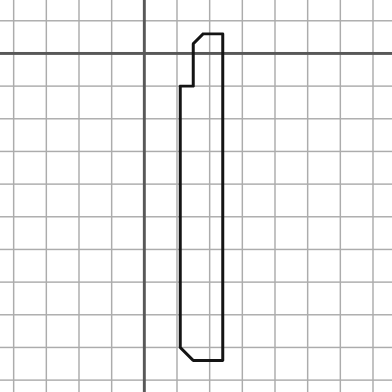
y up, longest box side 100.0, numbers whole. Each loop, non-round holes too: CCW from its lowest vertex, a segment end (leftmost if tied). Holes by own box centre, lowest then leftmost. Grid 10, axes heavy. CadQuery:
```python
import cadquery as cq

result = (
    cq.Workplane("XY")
    .moveTo(15.0, -94.0)
    .lineTo(24.0, -94.0)
    .lineTo(24.0, 6.0)
    .lineTo(18.0, 6.0)
    .lineTo(15.0, 3.0)
    .lineTo(15.0, -10.0)
    .lineTo(11.0, -10.0)
    .lineTo(11.0, -90.0)
    .close()
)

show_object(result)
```